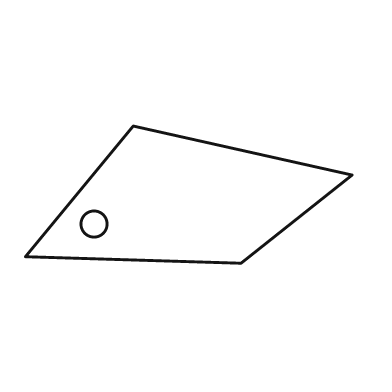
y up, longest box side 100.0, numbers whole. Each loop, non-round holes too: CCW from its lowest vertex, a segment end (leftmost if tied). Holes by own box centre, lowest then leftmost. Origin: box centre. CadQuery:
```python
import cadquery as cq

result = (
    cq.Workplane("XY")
    .moveTo(16.0, -21.0)
    .lineTo(50.0, 6.0)
    .lineTo(-17.0, 21.0)
    .lineTo(-50.0, -19.0)
    .close()
    .moveTo(-29.0, -9.0)
    .circle(4.0)
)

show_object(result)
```